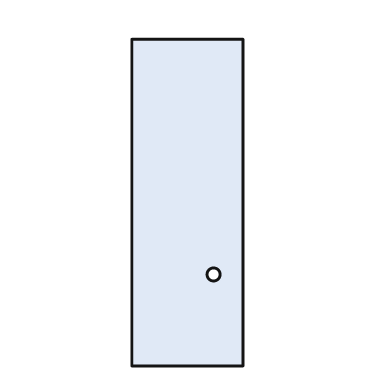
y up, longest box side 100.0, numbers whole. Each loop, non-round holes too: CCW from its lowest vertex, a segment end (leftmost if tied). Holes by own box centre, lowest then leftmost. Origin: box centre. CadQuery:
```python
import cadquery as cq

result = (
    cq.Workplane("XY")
    .moveTo(-17.0, -50.0)
    .lineTo(17.0, -50.0)
    .lineTo(17.0, 50.0)
    .lineTo(-17.0, 50.0)
    .close()
    .moveTo(8.0, -22.0)
    .circle(2.0)
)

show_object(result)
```